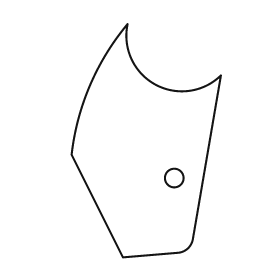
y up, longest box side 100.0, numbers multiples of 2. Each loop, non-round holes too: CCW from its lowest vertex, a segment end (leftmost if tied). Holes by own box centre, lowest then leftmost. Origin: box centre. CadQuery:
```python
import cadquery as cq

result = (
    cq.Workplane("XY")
    .moveTo(-10.0, -50.0)
    .lineTo(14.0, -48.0)
    .threePointArc((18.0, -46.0), (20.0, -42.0))
    .lineTo(32.0, 28.0)
    .threePointArc((4.0, 24.0), (-8.0, 50.0))
    .threePointArc((-24.0, 24.0), (-32.0, -6.0))
    .close()
    .moveTo(12.0, -16.0)
    .circle(4.0)
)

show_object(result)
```